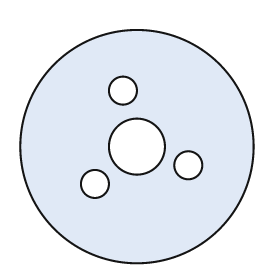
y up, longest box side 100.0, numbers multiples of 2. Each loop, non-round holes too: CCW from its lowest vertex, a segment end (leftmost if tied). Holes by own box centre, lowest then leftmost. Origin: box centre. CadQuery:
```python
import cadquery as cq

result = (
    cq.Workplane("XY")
    .moveTo(0.0, 0.0)
    .circle(50.0)
    .moveTo(-18.0, -16.0)
    .circle(6.0)
    .moveTo(22.0, -8.0)
    .circle(6.0)
    .moveTo(0.0, 0.0)
    .circle(12.0)
    .moveTo(-6.0, 24.0)
    .circle(6.0)
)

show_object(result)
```